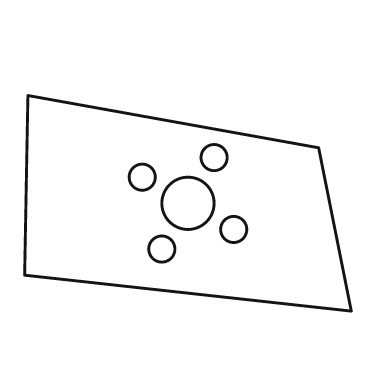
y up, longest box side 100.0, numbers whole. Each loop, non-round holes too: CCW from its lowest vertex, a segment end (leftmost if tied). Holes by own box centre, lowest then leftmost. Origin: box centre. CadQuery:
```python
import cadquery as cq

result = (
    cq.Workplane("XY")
    .moveTo(50.0, -33.0)
    .lineTo(40.0, 17.0)
    .lineTo(-49.0, 33.0)
    .lineTo(-50.0, -22.0)
    .close()
    .moveTo(-8.0, -14.0)
    .circle(4.0)
    .moveTo(14.0, -8.0)
    .circle(4.0)
    .moveTo(0.0, 0.0)
    .circle(8.0)
    .moveTo(-14.0, 8.0)
    .circle(4.0)
    .moveTo(8.0, 14.0)
    .circle(4.0)
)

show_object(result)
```